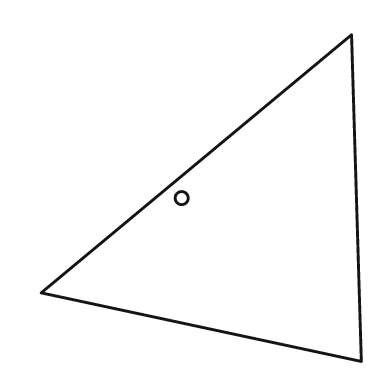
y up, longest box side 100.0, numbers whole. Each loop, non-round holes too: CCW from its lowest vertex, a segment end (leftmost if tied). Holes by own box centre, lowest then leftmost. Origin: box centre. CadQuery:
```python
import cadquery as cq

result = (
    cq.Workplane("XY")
    .moveTo(49.0, -50.0)
    .lineTo(46.0, 50.0)
    .lineTo(-49.0, -29.0)
    .close()
    .moveTo(-6.0, 0.0)
    .circle(2.0)
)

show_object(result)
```